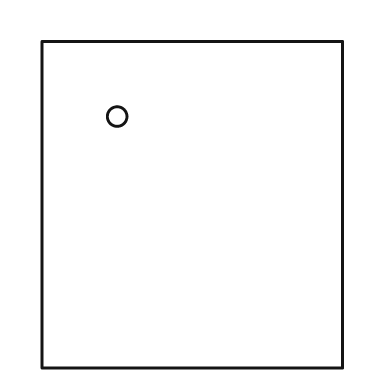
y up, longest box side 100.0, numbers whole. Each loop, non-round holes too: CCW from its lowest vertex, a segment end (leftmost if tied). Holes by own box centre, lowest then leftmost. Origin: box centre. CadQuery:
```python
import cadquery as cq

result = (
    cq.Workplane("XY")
    .moveTo(-46.0, -50.0)
    .lineTo(46.0, -50.0)
    .lineTo(46.0, 50.0)
    .lineTo(-46.0, 50.0)
    .close()
    .moveTo(-23.0, 27.0)
    .circle(3.0)
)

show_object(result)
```